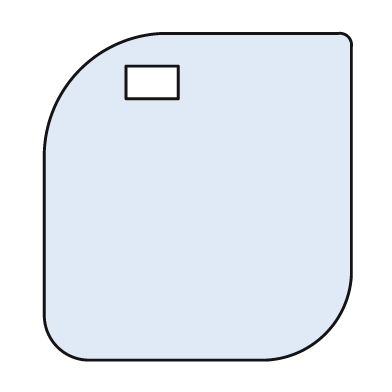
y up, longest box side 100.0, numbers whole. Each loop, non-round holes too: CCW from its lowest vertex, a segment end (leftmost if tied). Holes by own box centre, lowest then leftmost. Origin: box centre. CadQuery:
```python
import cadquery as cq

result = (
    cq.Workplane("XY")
    .moveTo(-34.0, -50.0)
    .lineTo(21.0, -50.0)
    .threePointArc((39.0, -42.0), (47.0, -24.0))
    .lineTo(47.0, 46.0)
    .threePointArc((46.0, 49.0), (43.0, 50.0))
    .lineTo(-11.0, 50.0)
    .threePointArc((-36.0, 39.0), (-47.0, 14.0))
    .lineTo(-47.0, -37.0)
    .threePointArc((-43.0, -46.0), (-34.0, -50.0))
    .close()
    .moveTo(-22.0, 30.0)
    .lineTo(-6.0, 30.0)
    .lineTo(-6.0, 40.0)
    .lineTo(-22.0, 40.0)
    .close()
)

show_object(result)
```